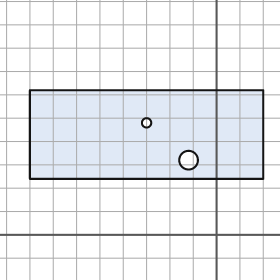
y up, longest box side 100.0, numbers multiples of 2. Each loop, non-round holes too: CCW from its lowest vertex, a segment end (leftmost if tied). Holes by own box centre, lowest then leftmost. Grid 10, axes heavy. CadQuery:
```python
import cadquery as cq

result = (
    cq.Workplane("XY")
    .moveTo(-80.0, 24.0)
    .lineTo(20.0, 24.0)
    .lineTo(20.0, 62.0)
    .lineTo(-80.0, 62.0)
    .close()
    .moveTo(-12.0, 32.0)
    .circle(4.0)
    .moveTo(-30.0, 48.0)
    .circle(2.0)
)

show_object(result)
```